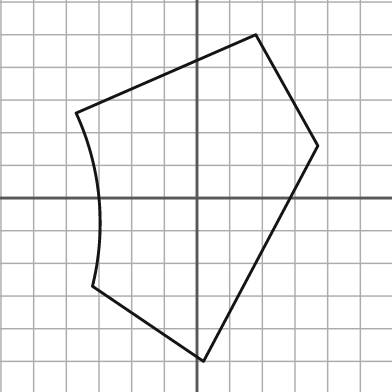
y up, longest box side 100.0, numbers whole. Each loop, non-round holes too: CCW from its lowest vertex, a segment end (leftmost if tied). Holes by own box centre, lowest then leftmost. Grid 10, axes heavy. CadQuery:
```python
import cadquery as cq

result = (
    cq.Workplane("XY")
    .moveTo(2.0, -50.0)
    .lineTo(37.0, 16.0)
    .lineTo(18.0, 50.0)
    .lineTo(-37.0, 26.0)
    .threePointArc((-30.0, 0.0), (-32.0, -27.0))
    .close()
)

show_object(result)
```